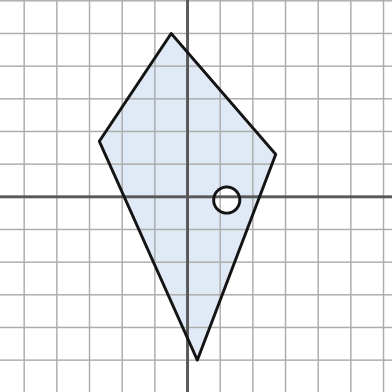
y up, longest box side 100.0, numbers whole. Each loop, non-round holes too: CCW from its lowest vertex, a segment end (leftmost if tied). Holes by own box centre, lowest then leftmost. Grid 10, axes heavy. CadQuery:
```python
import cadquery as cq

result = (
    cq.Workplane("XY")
    .moveTo(3.0, -50.0)
    .lineTo(27.0, 13.0)
    .lineTo(-5.0, 50.0)
    .lineTo(-27.0, 17.0)
    .close()
    .moveTo(12.0, -1.0)
    .circle(4.0)
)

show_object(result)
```